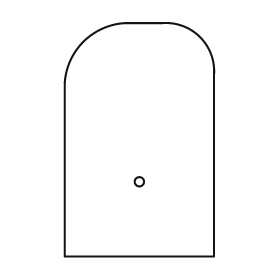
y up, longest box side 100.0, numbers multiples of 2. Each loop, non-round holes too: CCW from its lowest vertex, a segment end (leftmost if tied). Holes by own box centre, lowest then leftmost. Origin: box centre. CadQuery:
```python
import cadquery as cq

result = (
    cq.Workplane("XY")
    .moveTo(-32.0, -50.0)
    .lineTo(32.0, -50.0)
    .lineTo(32.0, 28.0)
    .threePointArc((26.0, 44.0), (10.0, 50.0))
    .lineTo(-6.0, 50.0)
    .threePointArc((-24.0, 42.0), (-32.0, 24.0))
    .close()
    .moveTo(0.0, -18.0)
    .circle(2.0)
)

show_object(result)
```